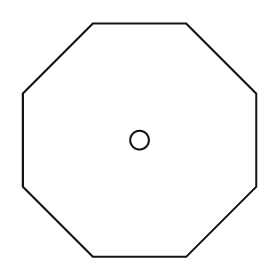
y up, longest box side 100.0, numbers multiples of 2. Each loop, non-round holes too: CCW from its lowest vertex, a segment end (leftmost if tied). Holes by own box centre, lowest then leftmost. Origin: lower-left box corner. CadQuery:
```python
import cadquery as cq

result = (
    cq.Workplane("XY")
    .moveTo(30.0, 0.0)
    .lineTo(70.0, 0.0)
    .lineTo(100.0, 30.0)
    .lineTo(100.0, 70.0)
    .lineTo(70.0, 100.0)
    .lineTo(30.0, 100.0)
    .lineTo(0.0, 70.0)
    .lineTo(0.0, 30.0)
    .close()
    .moveTo(50.0, 50.0)
    .circle(4.0)
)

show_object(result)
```